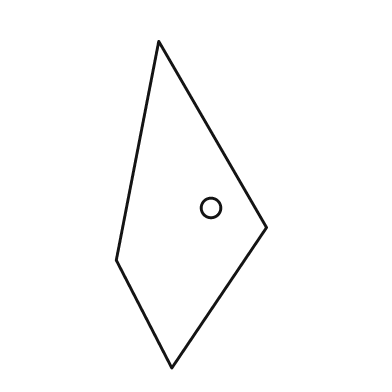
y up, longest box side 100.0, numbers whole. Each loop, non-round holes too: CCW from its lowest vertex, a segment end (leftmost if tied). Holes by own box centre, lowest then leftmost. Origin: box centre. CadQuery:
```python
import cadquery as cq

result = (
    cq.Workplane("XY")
    .moveTo(-6.0, -50.0)
    .lineTo(23.0, -7.0)
    .lineTo(-10.0, 50.0)
    .lineTo(-23.0, -17.0)
    .close()
    .moveTo(6.0, -1.0)
    .circle(3.0)
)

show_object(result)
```